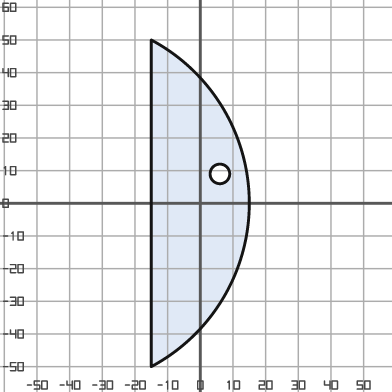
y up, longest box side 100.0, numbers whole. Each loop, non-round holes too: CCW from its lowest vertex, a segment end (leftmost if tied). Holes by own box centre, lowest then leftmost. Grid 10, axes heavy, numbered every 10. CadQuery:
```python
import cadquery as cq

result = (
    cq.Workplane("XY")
    .moveTo(-15.0, -50.0)
    .threePointArc((15.0, 0.0), (-15.0, 50.0))
    .close()
    .moveTo(6.0, 9.0)
    .circle(3.0)
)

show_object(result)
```